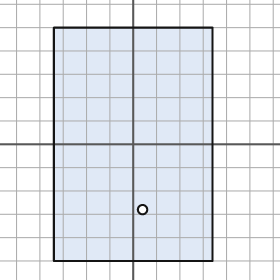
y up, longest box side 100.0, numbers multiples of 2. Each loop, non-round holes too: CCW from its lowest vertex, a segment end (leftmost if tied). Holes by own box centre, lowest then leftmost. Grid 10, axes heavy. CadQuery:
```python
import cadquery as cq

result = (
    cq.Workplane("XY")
    .moveTo(-34.0, -50.0)
    .lineTo(34.0, -50.0)
    .lineTo(34.0, 50.0)
    .lineTo(-34.0, 50.0)
    .close()
    .moveTo(4.0, -28.0)
    .circle(2.0)
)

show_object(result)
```